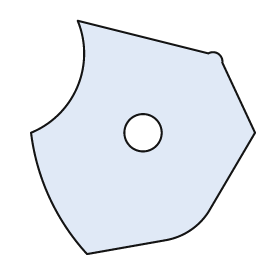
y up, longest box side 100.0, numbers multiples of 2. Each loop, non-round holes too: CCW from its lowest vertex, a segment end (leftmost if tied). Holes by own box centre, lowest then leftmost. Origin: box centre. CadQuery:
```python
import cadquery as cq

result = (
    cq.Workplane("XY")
    .moveTo(-24.0, -50.0)
    .lineTo(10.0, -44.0)
    .threePointArc((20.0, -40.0), (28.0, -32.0))
    .lineTo(48.0, 2.0)
    .lineTo(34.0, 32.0)
    .threePointArc((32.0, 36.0), (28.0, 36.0))
    .lineTo(-28.0, 50.0)
    .threePointArc((-28.0, 22.0), (-48.0, 2.0))
    .threePointArc((-40.0, -26.0), (-24.0, -50.0))
    .close()
    .moveTo(0.0, 2.0)
    .circle(8.0)
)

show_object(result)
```